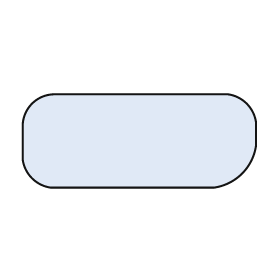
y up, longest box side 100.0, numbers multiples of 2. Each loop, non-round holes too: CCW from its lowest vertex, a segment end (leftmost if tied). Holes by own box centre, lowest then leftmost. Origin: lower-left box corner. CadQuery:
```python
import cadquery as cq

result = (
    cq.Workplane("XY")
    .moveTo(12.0, 0.0)
    .lineTo(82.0, 0.0)
    .threePointArc((94.0, 6.0), (100.0, 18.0))
    .lineTo(100.0, 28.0)
    .threePointArc((96.0, 36.0), (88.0, 40.0))
    .lineTo(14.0, 40.0)
    .threePointArc((4.0, 36.0), (0.0, 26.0))
    .lineTo(0.0, 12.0)
    .threePointArc((4.0, 4.0), (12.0, 0.0))
    .close()
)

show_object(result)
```